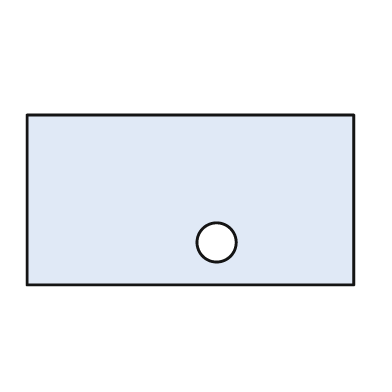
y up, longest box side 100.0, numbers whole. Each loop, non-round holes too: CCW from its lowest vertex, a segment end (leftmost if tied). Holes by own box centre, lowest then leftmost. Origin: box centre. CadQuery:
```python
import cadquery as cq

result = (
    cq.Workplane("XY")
    .moveTo(-50.0, -26.0)
    .lineTo(50.0, -26.0)
    .lineTo(50.0, 26.0)
    .lineTo(-50.0, 26.0)
    .close()
    .moveTo(8.0, -13.0)
    .circle(6.0)
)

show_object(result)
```